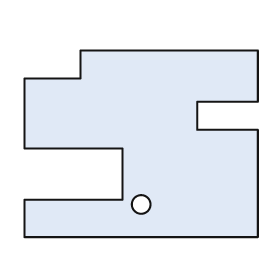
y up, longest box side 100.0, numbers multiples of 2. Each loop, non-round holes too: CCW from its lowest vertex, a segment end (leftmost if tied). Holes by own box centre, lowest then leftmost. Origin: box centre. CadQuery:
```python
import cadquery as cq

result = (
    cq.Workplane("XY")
    .moveTo(-50.0, -40.0)
    .lineTo(50.0, -40.0)
    .lineTo(50.0, 6.0)
    .lineTo(24.0, 6.0)
    .lineTo(24.0, 18.0)
    .lineTo(50.0, 18.0)
    .lineTo(50.0, 40.0)
    .lineTo(-26.0, 40.0)
    .lineTo(-26.0, 28.0)
    .lineTo(-50.0, 28.0)
    .lineTo(-50.0, -2.0)
    .lineTo(-8.0, -2.0)
    .lineTo(-8.0, -24.0)
    .lineTo(-50.0, -24.0)
    .close()
    .moveTo(0.0, -26.0)
    .circle(4.0)
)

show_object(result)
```